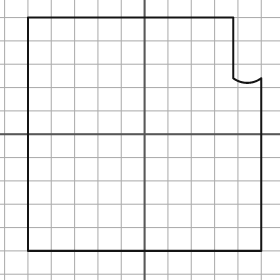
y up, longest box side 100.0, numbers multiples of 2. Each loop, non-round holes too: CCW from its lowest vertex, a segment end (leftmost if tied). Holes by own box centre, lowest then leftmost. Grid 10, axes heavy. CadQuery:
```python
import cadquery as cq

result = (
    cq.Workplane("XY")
    .moveTo(-50.0, -50.0)
    .lineTo(50.0, -50.0)
    .lineTo(50.0, 24.0)
    .threePointArc((44.0, 22.0), (38.0, 24.0))
    .lineTo(38.0, 50.0)
    .lineTo(-50.0, 50.0)
    .close()
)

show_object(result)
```